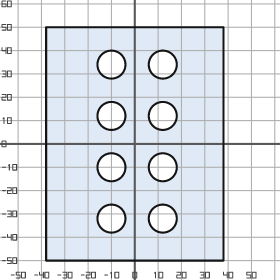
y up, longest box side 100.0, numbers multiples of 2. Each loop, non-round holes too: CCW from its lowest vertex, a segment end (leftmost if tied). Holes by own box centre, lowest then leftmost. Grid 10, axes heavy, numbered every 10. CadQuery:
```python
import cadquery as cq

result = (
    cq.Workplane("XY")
    .moveTo(-38.0, -50.0)
    .lineTo(38.0, -50.0)
    .lineTo(38.0, 50.0)
    .lineTo(-38.0, 50.0)
    .close()
    .moveTo(-10.0, -32.0)
    .circle(6.0)
    .moveTo(12.0, -32.0)
    .circle(6.0)
    .moveTo(-10.0, -10.0)
    .circle(6.0)
    .moveTo(12.0, -10.0)
    .circle(6.0)
    .moveTo(-10.0, 12.0)
    .circle(6.0)
    .moveTo(12.0, 12.0)
    .circle(6.0)
    .moveTo(-10.0, 34.0)
    .circle(6.0)
    .moveTo(12.0, 34.0)
    .circle(6.0)
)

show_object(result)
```